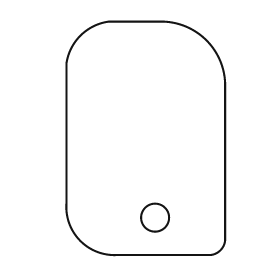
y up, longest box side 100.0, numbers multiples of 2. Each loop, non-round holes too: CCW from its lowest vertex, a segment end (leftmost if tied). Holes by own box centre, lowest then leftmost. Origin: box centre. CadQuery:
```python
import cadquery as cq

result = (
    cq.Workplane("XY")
    .moveTo(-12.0, -50.0)
    .lineTo(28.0, -50.0)
    .threePointArc((32.0, -48.0), (34.0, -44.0))
    .lineTo(34.0, 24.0)
    .threePointArc((26.0, 42.0), (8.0, 50.0))
    .lineTo(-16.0, 50.0)
    .threePointArc((-28.0, 44.0), (-34.0, 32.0))
    .lineTo(-34.0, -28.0)
    .threePointArc((-28.0, -44.0), (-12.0, -50.0))
    .close()
    .moveTo(4.0, -34.0)
    .circle(6.0)
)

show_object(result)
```